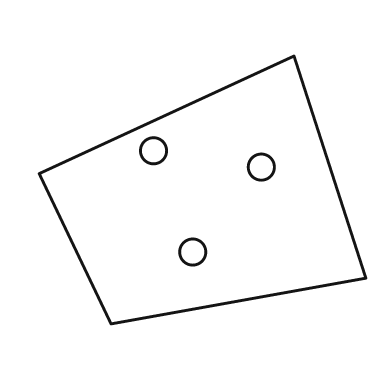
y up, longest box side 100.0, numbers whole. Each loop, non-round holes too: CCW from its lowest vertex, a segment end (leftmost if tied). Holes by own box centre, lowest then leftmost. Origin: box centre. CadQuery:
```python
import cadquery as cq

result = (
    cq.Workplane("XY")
    .moveTo(-28.0, -41.0)
    .lineTo(50.0, -27.0)
    .lineTo(28.0, 41.0)
    .lineTo(-50.0, 5.0)
    .close()
    .moveTo(-3.0, -19.0)
    .circle(4.0)
    .moveTo(18.0, 7.0)
    .circle(4.0)
    .moveTo(-15.0, 12.0)
    .circle(4.0)
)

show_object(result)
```